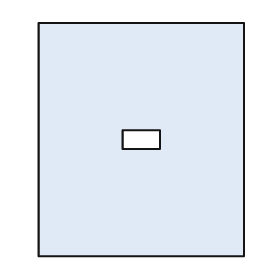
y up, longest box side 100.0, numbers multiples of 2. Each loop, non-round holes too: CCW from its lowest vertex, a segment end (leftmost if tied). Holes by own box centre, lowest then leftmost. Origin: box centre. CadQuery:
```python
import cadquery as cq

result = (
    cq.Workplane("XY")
    .moveTo(-44.0, -50.0)
    .lineTo(44.0, -50.0)
    .lineTo(44.0, 50.0)
    .lineTo(-44.0, 50.0)
    .close()
    .moveTo(-8.0, -4.0)
    .lineTo(8.0, -4.0)
    .lineTo(8.0, 4.0)
    .lineTo(-8.0, 4.0)
    .close()
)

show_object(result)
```